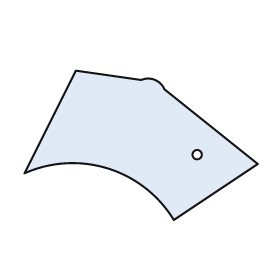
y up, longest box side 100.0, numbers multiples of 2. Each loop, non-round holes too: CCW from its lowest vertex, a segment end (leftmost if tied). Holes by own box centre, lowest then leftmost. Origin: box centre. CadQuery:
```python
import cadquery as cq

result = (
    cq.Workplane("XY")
    .moveTo(14.0, -32.0)
    .lineTo(50.0, -8.0)
    .lineTo(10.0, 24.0)
    .threePointArc((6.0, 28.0), (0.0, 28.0))
    .lineTo(-28.0, 32.0)
    .lineTo(-50.0, -12.0)
    .threePointArc((-14.0, -10.0), (14.0, -32.0))
    .close()
    .moveTo(24.0, -4.0)
    .circle(2.0)
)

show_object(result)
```